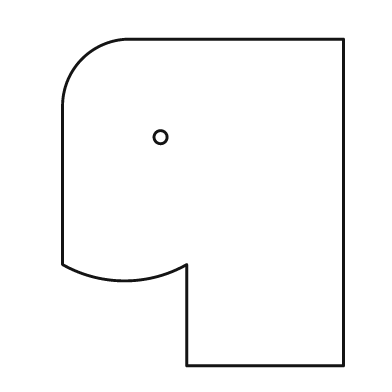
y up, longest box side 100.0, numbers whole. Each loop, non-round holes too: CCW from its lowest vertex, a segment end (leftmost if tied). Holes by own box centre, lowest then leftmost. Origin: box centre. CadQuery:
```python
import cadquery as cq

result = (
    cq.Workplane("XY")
    .moveTo(-5.0, -50.0)
    .lineTo(43.0, -50.0)
    .lineTo(43.0, 50.0)
    .lineTo(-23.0, 50.0)
    .threePointArc((-37.0, 44.0), (-43.0, 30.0))
    .lineTo(-43.0, -19.0)
    .threePointArc((-24.0, -24.0), (-5.0, -19.0))
    .close()
    .moveTo(-13.0, 20.0)
    .circle(2.0)
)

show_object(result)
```